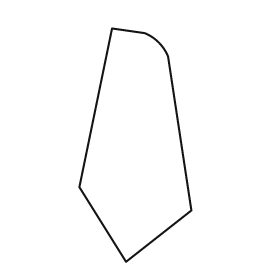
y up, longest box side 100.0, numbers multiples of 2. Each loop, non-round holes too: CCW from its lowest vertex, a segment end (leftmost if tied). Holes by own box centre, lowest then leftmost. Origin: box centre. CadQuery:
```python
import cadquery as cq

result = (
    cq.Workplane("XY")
    .moveTo(-4.0, -50.0)
    .lineTo(24.0, -28.0)
    .lineTo(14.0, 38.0)
    .threePointArc((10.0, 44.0), (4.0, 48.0))
    .lineTo(-10.0, 50.0)
    .lineTo(-24.0, -18.0)
    .close()
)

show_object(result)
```